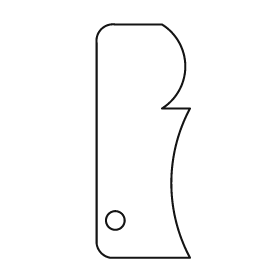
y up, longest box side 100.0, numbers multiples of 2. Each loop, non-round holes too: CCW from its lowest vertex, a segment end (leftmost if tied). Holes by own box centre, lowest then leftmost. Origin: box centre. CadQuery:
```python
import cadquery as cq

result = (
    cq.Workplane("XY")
    .moveTo(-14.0, -50.0)
    .lineTo(20.0, -50.0)
    .threePointArc((12.0, -18.0), (20.0, 14.0))
    .lineTo(8.0, 14.0)
    .threePointArc((18.0, 32.0), (8.0, 50.0))
    .lineTo(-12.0, 50.0)
    .threePointArc((-18.0, 48.0), (-20.0, 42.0))
    .lineTo(-20.0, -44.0)
    .threePointArc((-18.0, -48.0), (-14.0, -50.0))
    .close()
    .moveTo(-12.0, -34.0)
    .circle(4.0)
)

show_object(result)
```